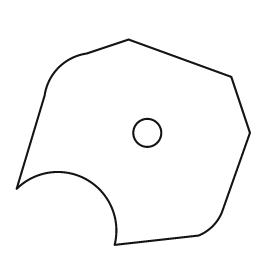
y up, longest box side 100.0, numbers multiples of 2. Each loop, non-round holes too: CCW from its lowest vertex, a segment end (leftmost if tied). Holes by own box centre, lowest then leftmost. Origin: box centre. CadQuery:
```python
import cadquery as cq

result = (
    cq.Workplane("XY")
    .moveTo(-8.0, -44.0)
    .lineTo(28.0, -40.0)
    .threePointArc((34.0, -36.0), (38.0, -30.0))
    .lineTo(50.0, 4.0)
    .lineTo(42.0, 28.0)
    .lineTo(-2.0, 44.0)
    .lineTo(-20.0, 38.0)
    .threePointArc((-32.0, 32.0), (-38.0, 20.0))
    .lineTo(-50.0, -20.0)
    .threePointArc((-20.0, -16.0), (-8.0, -44.0))
    .close()
    .moveTo(6.0, 4.0)
    .circle(6.0)
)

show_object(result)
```